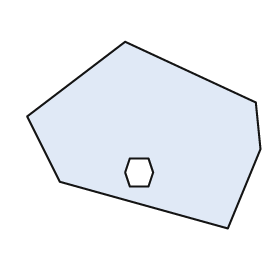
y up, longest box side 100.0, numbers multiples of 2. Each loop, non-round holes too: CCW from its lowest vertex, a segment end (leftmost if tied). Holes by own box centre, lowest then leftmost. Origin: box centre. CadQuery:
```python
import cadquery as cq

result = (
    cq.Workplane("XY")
    .moveTo(36.0, -40.0)
    .lineTo(50.0, -6.0)
    .lineTo(48.0, 14.0)
    .lineTo(-8.0, 40.0)
    .lineTo(-50.0, 8.0)
    .lineTo(-36.0, -20.0)
    .close()
    .moveTo(-6.0, -22.0)
    .lineTo(2.0, -22.0)
    .lineTo(4.0, -16.0)
    .lineTo(2.0, -10.0)
    .lineTo(-6.0, -10.0)
    .lineTo(-8.0, -16.0)
    .close()
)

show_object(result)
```